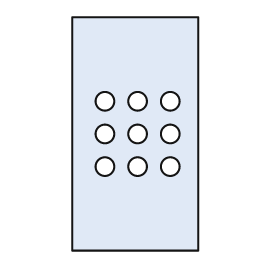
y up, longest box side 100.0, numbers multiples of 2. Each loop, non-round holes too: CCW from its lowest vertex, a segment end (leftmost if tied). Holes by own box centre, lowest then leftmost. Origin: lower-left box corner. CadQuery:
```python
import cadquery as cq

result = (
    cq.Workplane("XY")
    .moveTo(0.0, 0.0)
    .lineTo(54.0, 0.0)
    .lineTo(54.0, 100.0)
    .lineTo(0.0, 100.0)
    .close()
    .moveTo(14.0, 36.0)
    .circle(4.0)
    .moveTo(28.0, 36.0)
    .circle(4.0)
    .moveTo(42.0, 36.0)
    .circle(4.0)
    .moveTo(14.0, 50.0)
    .circle(4.0)
    .moveTo(28.0, 50.0)
    .circle(4.0)
    .moveTo(42.0, 50.0)
    .circle(4.0)
    .moveTo(14.0, 64.0)
    .circle(4.0)
    .moveTo(28.0, 64.0)
    .circle(4.0)
    .moveTo(42.0, 64.0)
    .circle(4.0)
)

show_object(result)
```